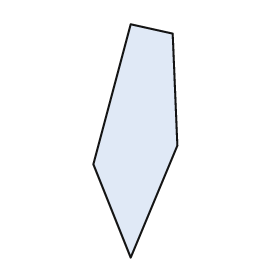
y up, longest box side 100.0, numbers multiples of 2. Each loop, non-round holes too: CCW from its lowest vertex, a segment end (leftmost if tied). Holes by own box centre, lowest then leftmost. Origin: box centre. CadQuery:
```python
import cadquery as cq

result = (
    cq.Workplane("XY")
    .moveTo(-2.0, -50.0)
    .lineTo(18.0, -2.0)
    .lineTo(16.0, 46.0)
    .lineTo(-2.0, 50.0)
    .lineTo(-18.0, -10.0)
    .close()
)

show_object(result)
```